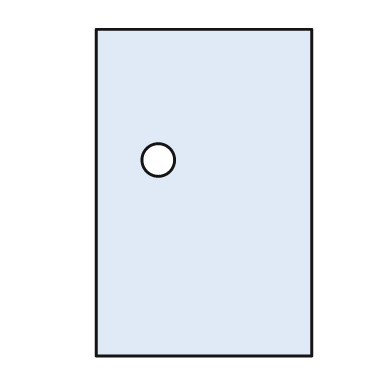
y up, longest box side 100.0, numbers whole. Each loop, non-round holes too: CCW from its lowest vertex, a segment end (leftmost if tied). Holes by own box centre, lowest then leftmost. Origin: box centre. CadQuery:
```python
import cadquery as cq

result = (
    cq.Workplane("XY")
    .moveTo(-33.0, -50.0)
    .lineTo(33.0, -50.0)
    .lineTo(33.0, 50.0)
    .lineTo(-33.0, 50.0)
    .close()
    .moveTo(-14.0, 10.0)
    .circle(5.0)
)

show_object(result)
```